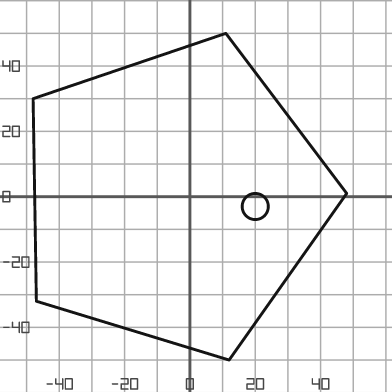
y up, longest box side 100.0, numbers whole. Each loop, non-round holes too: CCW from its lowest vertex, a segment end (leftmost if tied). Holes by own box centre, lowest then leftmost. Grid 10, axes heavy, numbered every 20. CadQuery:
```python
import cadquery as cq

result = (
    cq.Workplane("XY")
    .moveTo(12.0, -50.0)
    .lineTo(48.0, 1.0)
    .lineTo(11.0, 50.0)
    .lineTo(-48.0, 30.0)
    .lineTo(-47.0, -32.0)
    .close()
    .moveTo(20.0, -3.0)
    .circle(4.0)
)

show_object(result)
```